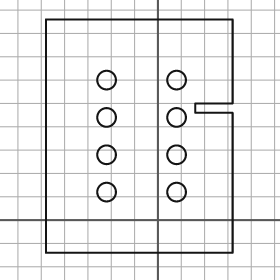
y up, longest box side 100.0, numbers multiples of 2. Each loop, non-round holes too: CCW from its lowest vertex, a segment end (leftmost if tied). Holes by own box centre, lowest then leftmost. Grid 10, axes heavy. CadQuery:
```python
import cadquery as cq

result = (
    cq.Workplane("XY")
    .moveTo(-48.0, -14.0)
    .lineTo(32.0, -14.0)
    .lineTo(32.0, 46.0)
    .lineTo(16.0, 46.0)
    .lineTo(16.0, 50.0)
    .lineTo(32.0, 50.0)
    .lineTo(32.0, 86.0)
    .lineTo(-48.0, 86.0)
    .close()
    .moveTo(-22.0, 12.0)
    .circle(4.0)
    .moveTo(8.0, 12.0)
    .circle(4.0)
    .moveTo(-22.0, 28.0)
    .circle(4.0)
    .moveTo(8.0, 28.0)
    .circle(4.0)
    .moveTo(-22.0, 44.0)
    .circle(4.0)
    .moveTo(8.0, 44.0)
    .circle(4.0)
    .moveTo(-22.0, 60.0)
    .circle(4.0)
    .moveTo(8.0, 60.0)
    .circle(4.0)
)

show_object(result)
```